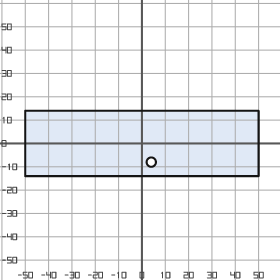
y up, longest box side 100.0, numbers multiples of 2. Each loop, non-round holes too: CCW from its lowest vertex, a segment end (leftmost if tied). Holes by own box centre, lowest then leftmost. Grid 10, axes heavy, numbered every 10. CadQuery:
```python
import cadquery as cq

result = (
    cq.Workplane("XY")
    .moveTo(-50.0, -14.0)
    .lineTo(50.0, -14.0)
    .lineTo(50.0, 14.0)
    .lineTo(-50.0, 14.0)
    .close()
    .moveTo(4.0, -8.0)
    .circle(2.0)
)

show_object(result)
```